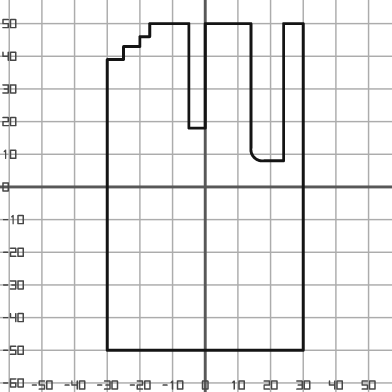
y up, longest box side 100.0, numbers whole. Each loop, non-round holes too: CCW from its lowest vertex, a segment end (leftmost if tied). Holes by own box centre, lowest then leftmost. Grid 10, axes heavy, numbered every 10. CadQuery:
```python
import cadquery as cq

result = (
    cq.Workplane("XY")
    .moveTo(-30.0, -50.0)
    .lineTo(30.0, -50.0)
    .lineTo(30.0, 50.0)
    .lineTo(24.0, 50.0)
    .lineTo(24.0, 8.0)
    .lineTo(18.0, 8.0)
    .threePointArc((15.0, 9.0), (14.0, 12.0))
    .lineTo(14.0, 50.0)
    .lineTo(0.0, 50.0)
    .lineTo(0.0, 18.0)
    .lineTo(-5.0, 18.0)
    .lineTo(-5.0, 50.0)
    .lineTo(-17.0, 50.0)
    .lineTo(-17.0, 46.0)
    .lineTo(-20.0, 46.0)
    .lineTo(-20.0, 43.0)
    .lineTo(-25.0, 43.0)
    .lineTo(-25.0, 39.0)
    .lineTo(-30.0, 39.0)
    .close()
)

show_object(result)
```